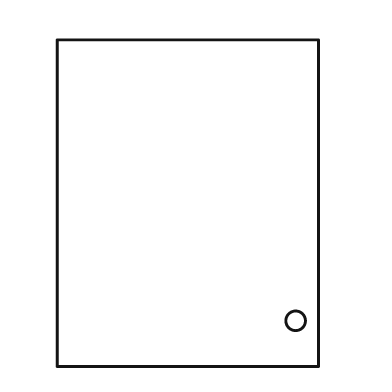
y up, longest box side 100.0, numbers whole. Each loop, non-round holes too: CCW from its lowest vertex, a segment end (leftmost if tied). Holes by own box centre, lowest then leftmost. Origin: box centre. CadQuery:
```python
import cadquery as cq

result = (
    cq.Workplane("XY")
    .moveTo(-40.0, -50.0)
    .lineTo(40.0, -50.0)
    .lineTo(40.0, 50.0)
    .lineTo(-40.0, 50.0)
    .close()
    .moveTo(33.0, -36.0)
    .circle(3.0)
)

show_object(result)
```